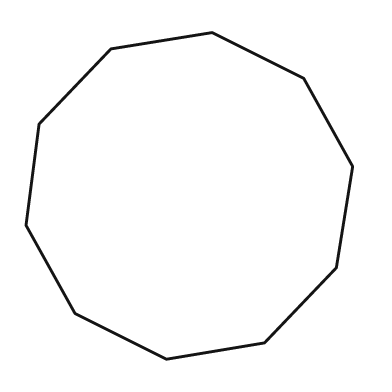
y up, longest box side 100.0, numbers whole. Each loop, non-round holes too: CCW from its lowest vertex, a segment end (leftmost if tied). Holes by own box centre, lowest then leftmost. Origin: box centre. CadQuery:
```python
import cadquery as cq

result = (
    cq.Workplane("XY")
    .moveTo(-7.0, -50.0)
    .lineTo(23.0, -45.0)
    .lineTo(45.0, -22.0)
    .lineTo(50.0, 9.0)
    .lineTo(35.0, 36.0)
    .lineTo(7.0, 50.0)
    .lineTo(-24.0, 45.0)
    .lineTo(-46.0, 22.0)
    .lineTo(-50.0, -9.0)
    .lineTo(-35.0, -36.0)
    .close()
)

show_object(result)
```